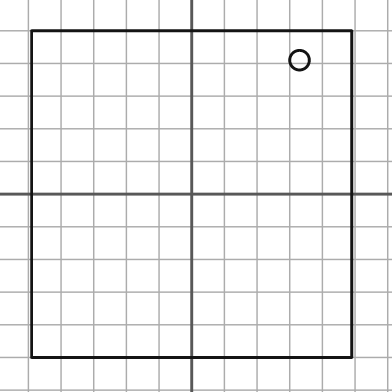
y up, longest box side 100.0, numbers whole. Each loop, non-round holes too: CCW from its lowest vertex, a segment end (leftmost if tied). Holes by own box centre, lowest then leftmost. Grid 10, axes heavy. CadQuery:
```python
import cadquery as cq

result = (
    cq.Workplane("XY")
    .moveTo(-49.0, -50.0)
    .lineTo(49.0, -50.0)
    .lineTo(49.0, 50.0)
    .lineTo(-49.0, 50.0)
    .close()
    .moveTo(33.0, 41.0)
    .circle(3.0)
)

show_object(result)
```